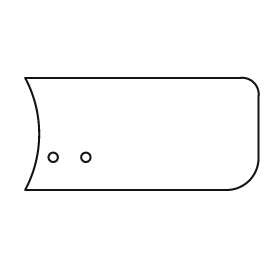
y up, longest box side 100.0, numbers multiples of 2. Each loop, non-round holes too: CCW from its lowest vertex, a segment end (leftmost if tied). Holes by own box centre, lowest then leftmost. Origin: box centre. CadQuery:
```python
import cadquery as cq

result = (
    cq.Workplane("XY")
    .moveTo(-50.0, -24.0)
    .lineTo(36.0, -24.0)
    .threePointArc((46.0, -20.0), (50.0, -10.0))
    .lineTo(50.0, 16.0)
    .threePointArc((48.0, 22.0), (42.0, 24.0))
    .lineTo(-50.0, 24.0)
    .threePointArc((-44.0, 0.0), (-50.0, -24.0))
    .close()
    .moveTo(-38.0, -10.0)
    .circle(2.0)
    .moveTo(-24.0, -10.0)
    .circle(2.0)
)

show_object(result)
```